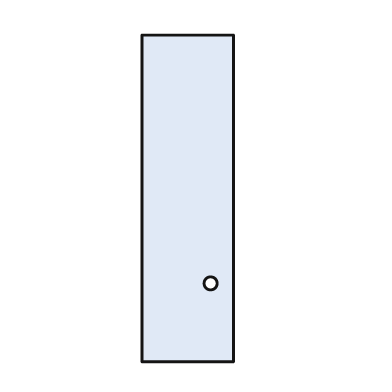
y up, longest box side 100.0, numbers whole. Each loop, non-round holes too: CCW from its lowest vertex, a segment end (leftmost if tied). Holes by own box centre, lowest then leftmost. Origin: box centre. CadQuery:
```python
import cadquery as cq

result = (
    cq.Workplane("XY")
    .moveTo(-14.0, -50.0)
    .lineTo(14.0, -50.0)
    .lineTo(14.0, 50.0)
    .lineTo(-14.0, 50.0)
    .close()
    .moveTo(7.0, -26.0)
    .circle(2.0)
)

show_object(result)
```